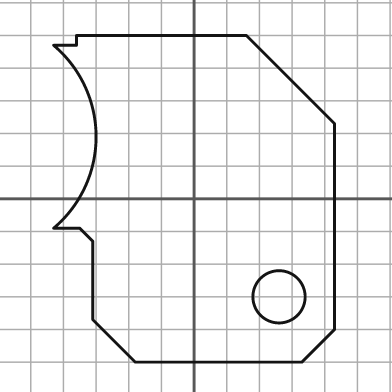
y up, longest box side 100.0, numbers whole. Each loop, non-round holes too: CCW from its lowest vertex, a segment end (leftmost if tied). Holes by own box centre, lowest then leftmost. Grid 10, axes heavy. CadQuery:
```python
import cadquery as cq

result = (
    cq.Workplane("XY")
    .moveTo(-18.0, -50.0)
    .lineTo(33.0, -50.0)
    .lineTo(43.0, -40.0)
    .lineTo(43.0, 23.0)
    .lineTo(16.0, 50.0)
    .lineTo(-36.0, 50.0)
    .lineTo(-36.0, 47.0)
    .lineTo(-43.0, 47.0)
    .threePointArc((-30.0, 19.0), (-43.0, -9.0))
    .lineTo(-35.0, -9.0)
    .lineTo(-31.0, -13.0)
    .lineTo(-31.0, -37.0)
    .close()
    .moveTo(26.0, -30.0)
    .circle(8.0)
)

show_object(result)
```